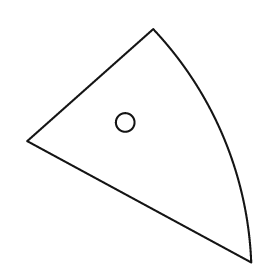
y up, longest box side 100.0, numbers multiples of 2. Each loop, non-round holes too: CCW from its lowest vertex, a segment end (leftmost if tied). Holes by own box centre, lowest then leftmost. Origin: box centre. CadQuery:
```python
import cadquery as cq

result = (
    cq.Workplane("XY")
    .moveTo(48.0, -50.0)
    .threePointArc((36.0, 4.0), (6.0, 50.0))
    .lineTo(-48.0, 2.0)
    .close()
    .moveTo(-6.0, 10.0)
    .circle(4.0)
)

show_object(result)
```